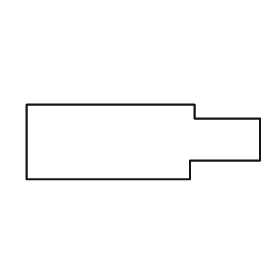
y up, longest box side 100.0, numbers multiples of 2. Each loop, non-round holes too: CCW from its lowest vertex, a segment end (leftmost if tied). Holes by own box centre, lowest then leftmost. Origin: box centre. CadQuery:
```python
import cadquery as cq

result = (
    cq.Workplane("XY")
    .moveTo(-50.0, -16.0)
    .lineTo(20.0, -16.0)
    .lineTo(20.0, -8.0)
    .lineTo(50.0, -8.0)
    .lineTo(50.0, 10.0)
    .lineTo(22.0, 10.0)
    .lineTo(22.0, 16.0)
    .lineTo(-50.0, 16.0)
    .close()
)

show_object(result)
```